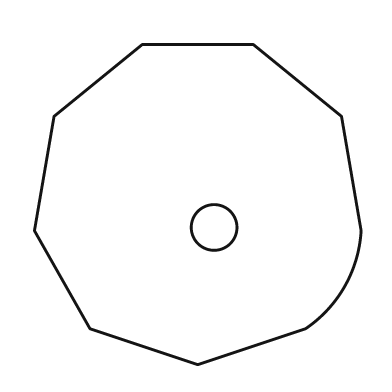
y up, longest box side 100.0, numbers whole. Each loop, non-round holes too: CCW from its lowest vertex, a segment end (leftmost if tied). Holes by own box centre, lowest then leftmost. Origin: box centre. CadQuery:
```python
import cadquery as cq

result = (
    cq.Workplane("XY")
    .moveTo(0.0, -49.0)
    .lineTo(33.0, -38.0)
    .threePointArc((45.0, -25.0), (50.0, -8.0))
    .lineTo(44.0, 27.0)
    .lineTo(17.0, 49.0)
    .lineTo(-17.0, 49.0)
    .lineTo(-44.0, 27.0)
    .lineTo(-50.0, -8.0)
    .lineTo(-33.0, -38.0)
    .close()
    .moveTo(5.0, -7.0)
    .circle(7.0)
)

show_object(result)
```